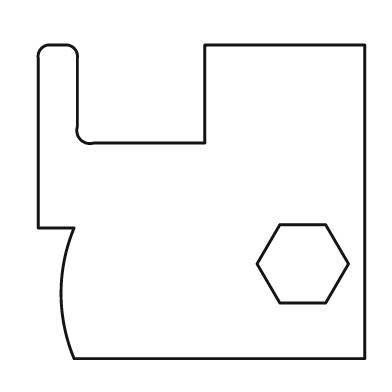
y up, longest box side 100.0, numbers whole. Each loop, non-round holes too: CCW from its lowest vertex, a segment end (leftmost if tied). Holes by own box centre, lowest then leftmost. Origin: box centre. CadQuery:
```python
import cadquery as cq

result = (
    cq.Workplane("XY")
    .moveTo(-39.0, -48.0)
    .lineTo(50.0, -48.0)
    .lineTo(50.0, 48.0)
    .lineTo(1.0, 48.0)
    .lineTo(1.0, 18.0)
    .lineTo(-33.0, 18.0)
    .threePointArc((-37.0, 19.0), (-38.0, 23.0))
    .lineTo(-38.0, 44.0)
    .threePointArc((-39.0, 47.0), (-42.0, 48.0))
    .lineTo(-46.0, 48.0)
    .threePointArc((-49.0, 47.0), (-50.0, 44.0))
    .lineTo(-50.0, -8.0)
    .lineTo(-39.0, -8.0)
    .threePointArc((-43.0, -28.0), (-39.0, -48.0))
    .close()
    .moveTo(24.0, -31.0)
    .lineTo(38.0, -31.0)
    .lineTo(45.0, -19.0)
    .lineTo(38.0, -7.0)
    .lineTo(24.0, -7.0)
    .lineTo(17.0, -19.0)
    .close()
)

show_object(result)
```